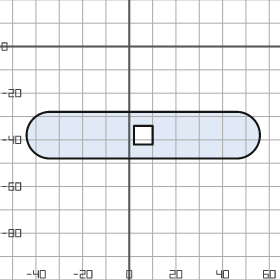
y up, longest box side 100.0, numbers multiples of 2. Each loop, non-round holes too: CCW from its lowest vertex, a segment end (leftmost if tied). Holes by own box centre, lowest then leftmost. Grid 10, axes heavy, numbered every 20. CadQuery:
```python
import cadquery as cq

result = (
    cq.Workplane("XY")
    .moveTo(-34.0, -48.0)
    .lineTo(46.0, -48.0)
    .threePointArc((56.0, -38.0), (46.0, -28.0))
    .lineTo(-34.0, -28.0)
    .threePointArc((-44.0, -38.0), (-34.0, -48.0))
    .close()
    .moveTo(2.0, -42.0)
    .lineTo(10.0, -42.0)
    .lineTo(10.0, -34.0)
    .lineTo(2.0, -34.0)
    .close()
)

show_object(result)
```